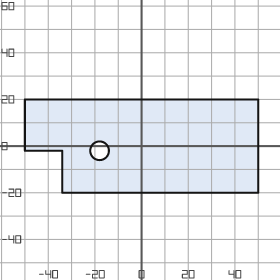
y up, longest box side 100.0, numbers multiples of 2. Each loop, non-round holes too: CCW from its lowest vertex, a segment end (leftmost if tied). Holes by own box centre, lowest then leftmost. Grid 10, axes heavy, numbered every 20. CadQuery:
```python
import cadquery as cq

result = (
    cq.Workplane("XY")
    .moveTo(-34.0, -20.0)
    .lineTo(50.0, -20.0)
    .lineTo(50.0, 20.0)
    .lineTo(-50.0, 20.0)
    .lineTo(-50.0, -2.0)
    .lineTo(-34.0, -2.0)
    .close()
    .moveTo(-18.0, -2.0)
    .circle(4.0)
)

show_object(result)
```